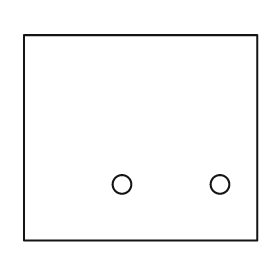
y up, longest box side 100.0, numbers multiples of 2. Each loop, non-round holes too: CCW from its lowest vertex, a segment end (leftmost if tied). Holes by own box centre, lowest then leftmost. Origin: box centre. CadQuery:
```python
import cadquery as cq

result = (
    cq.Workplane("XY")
    .moveTo(-50.0, -44.0)
    .lineTo(50.0, -44.0)
    .lineTo(50.0, 44.0)
    .lineTo(-50.0, 44.0)
    .close()
    .moveTo(-8.0, -20.0)
    .circle(4.0)
    .moveTo(34.0, -20.0)
    .circle(4.0)
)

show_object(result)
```